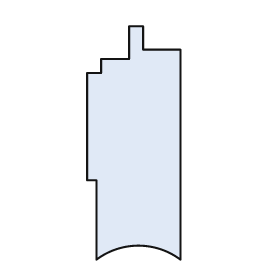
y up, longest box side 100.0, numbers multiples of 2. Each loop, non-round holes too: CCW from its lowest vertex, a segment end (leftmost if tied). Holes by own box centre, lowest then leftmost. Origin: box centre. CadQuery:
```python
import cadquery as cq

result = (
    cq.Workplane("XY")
    .moveTo(-16.0, -50.0)
    .threePointArc((2.0, -44.0), (20.0, -50.0))
    .lineTo(20.0, 40.0)
    .lineTo(4.0, 40.0)
    .lineTo(4.0, 50.0)
    .lineTo(-2.0, 50.0)
    .lineTo(-2.0, 36.0)
    .lineTo(-14.0, 36.0)
    .lineTo(-14.0, 30.0)
    .lineTo(-20.0, 30.0)
    .lineTo(-20.0, -16.0)
    .lineTo(-16.0, -16.0)
    .close()
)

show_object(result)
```